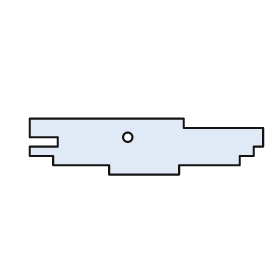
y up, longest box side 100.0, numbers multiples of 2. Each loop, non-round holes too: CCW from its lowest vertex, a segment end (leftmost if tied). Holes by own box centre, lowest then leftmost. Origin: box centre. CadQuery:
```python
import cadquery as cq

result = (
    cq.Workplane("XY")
    .moveTo(-16.0, -12.0)
    .lineTo(14.0, -12.0)
    .lineTo(14.0, -8.0)
    .lineTo(40.0, -8.0)
    .lineTo(40.0, -4.0)
    .lineTo(46.0, -4.0)
    .lineTo(46.0, 0.0)
    .lineTo(50.0, 0.0)
    .lineTo(50.0, 8.0)
    .lineTo(16.0, 8.0)
    .lineTo(16.0, 12.0)
    .lineTo(-50.0, 12.0)
    .lineTo(-50.0, 4.0)
    .lineTo(-38.0, 4.0)
    .lineTo(-38.0, 0.0)
    .lineTo(-50.0, 0.0)
    .lineTo(-50.0, -4.0)
    .lineTo(-40.0, -4.0)
    .lineTo(-40.0, -8.0)
    .lineTo(-16.0, -8.0)
    .close()
    .moveTo(-8.0, 4.0)
    .circle(2.0)
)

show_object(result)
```